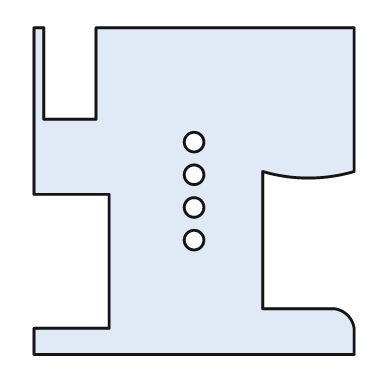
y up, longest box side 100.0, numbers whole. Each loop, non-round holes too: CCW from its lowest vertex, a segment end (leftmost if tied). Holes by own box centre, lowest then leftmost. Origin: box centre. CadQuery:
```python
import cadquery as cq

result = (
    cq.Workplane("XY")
    .moveTo(-49.0, -50.0)
    .lineTo(49.0, -50.0)
    .lineTo(49.0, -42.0)
    .threePointArc((47.0, -38.0), (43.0, -36.0))
    .lineTo(21.0, -36.0)
    .lineTo(21.0, 6.0)
    .threePointArc((35.0, 4.0), (49.0, 6.0))
    .lineTo(49.0, 50.0)
    .lineTo(-30.0, 50.0)
    .lineTo(-30.0, 22.0)
    .lineTo(-46.0, 22.0)
    .lineTo(-46.0, 50.0)
    .lineTo(-49.0, 50.0)
    .lineTo(-49.0, -1.0)
    .lineTo(-26.0, -1.0)
    .lineTo(-26.0, -42.0)
    .lineTo(-49.0, -42.0)
    .close()
    .moveTo(0.0, -15.0)
    .circle(3.0)
    .moveTo(0.0, -5.0)
    .circle(3.0)
    .moveTo(0.0, 5.0)
    .circle(3.0)
    .moveTo(0.0, 15.0)
    .circle(3.0)
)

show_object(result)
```